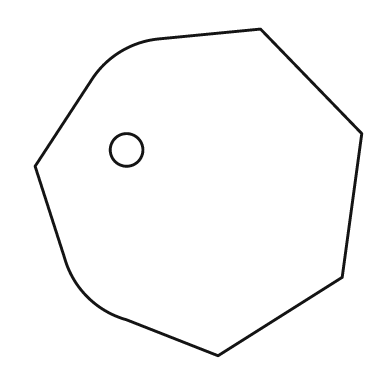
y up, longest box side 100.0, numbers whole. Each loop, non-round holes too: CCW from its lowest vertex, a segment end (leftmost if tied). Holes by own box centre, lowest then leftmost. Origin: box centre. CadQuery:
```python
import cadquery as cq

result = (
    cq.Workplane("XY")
    .moveTo(6.0, -50.0)
    .lineTo(44.0, -26.0)
    .lineTo(50.0, 18.0)
    .lineTo(19.0, 50.0)
    .lineTo(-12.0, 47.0)
    .threePointArc((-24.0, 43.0), (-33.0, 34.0))
    .lineTo(-50.0, 8.0)
    .lineTo(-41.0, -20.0)
    .threePointArc((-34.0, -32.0), (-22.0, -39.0))
    .close()
    .moveTo(-22.0, 13.0)
    .circle(5.0)
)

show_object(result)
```